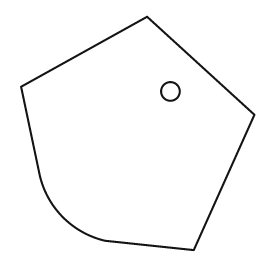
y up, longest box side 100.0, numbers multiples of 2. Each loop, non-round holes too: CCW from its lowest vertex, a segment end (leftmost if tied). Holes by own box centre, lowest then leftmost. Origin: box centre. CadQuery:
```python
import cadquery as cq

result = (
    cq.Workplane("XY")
    .moveTo(24.0, -50.0)
    .lineTo(50.0, 8.0)
    .lineTo(4.0, 50.0)
    .lineTo(-50.0, 20.0)
    .lineTo(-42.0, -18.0)
    .threePointArc((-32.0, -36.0), (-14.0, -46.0))
    .close()
    .moveTo(14.0, 18.0)
    .circle(4.0)
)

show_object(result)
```